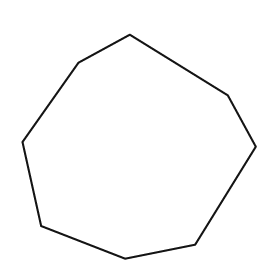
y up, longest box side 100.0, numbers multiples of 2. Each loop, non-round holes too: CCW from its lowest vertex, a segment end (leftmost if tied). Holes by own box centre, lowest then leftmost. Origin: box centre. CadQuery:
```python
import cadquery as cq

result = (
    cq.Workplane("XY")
    .moveTo(-6.0, -48.0)
    .lineTo(24.0, -42.0)
    .lineTo(50.0, 0.0)
    .lineTo(38.0, 22.0)
    .lineTo(-4.0, 48.0)
    .lineTo(-26.0, 36.0)
    .lineTo(-50.0, 2.0)
    .lineTo(-42.0, -34.0)
    .close()
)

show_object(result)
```